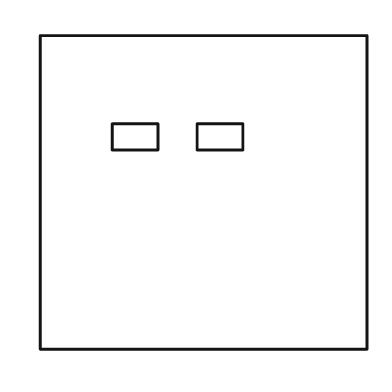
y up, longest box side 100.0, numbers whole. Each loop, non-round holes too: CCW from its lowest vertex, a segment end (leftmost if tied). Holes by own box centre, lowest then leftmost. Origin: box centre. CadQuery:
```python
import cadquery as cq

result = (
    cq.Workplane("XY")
    .moveTo(-50.0, -48.0)
    .lineTo(50.0, -48.0)
    .lineTo(50.0, 48.0)
    .lineTo(-50.0, 48.0)
    .close()
    .moveTo(-28.0, 13.0)
    .lineTo(-14.0, 13.0)
    .lineTo(-14.0, 21.0)
    .lineTo(-28.0, 21.0)
    .close()
    .moveTo(-2.0, 13.0)
    .lineTo(12.0, 13.0)
    .lineTo(12.0, 21.0)
    .lineTo(-2.0, 21.0)
    .close()
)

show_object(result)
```